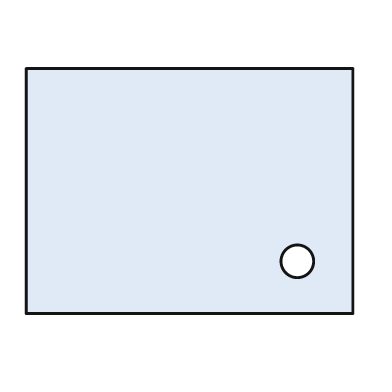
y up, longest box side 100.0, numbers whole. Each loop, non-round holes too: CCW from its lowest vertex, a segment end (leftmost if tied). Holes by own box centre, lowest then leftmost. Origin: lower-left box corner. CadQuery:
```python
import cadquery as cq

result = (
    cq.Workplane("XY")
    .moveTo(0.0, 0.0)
    .lineTo(100.0, 0.0)
    .lineTo(100.0, 75.0)
    .lineTo(0.0, 75.0)
    .close()
    .moveTo(83.0, 16.0)
    .circle(5.0)
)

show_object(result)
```